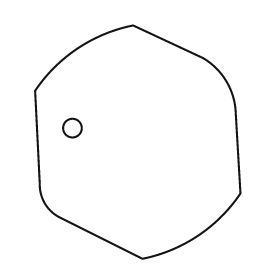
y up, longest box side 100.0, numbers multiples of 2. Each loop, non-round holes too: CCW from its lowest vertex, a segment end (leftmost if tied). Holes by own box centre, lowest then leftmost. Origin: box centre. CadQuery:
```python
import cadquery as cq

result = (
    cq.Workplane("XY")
    .moveTo(2.0, -50.0)
    .threePointArc((26.0, -40.0), (44.0, -22.0))
    .lineTo(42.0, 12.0)
    .threePointArc((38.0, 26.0), (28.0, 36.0))
    .lineTo(-2.0, 50.0)
    .threePointArc((-26.0, 40.0), (-44.0, 22.0))
    .lineTo(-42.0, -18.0)
    .threePointArc((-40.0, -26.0), (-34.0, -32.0))
    .close()
    .moveTo(-28.0, 6.0)
    .circle(4.0)
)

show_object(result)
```